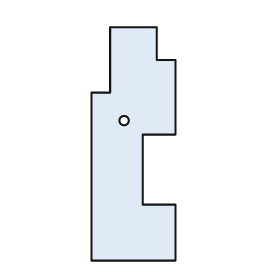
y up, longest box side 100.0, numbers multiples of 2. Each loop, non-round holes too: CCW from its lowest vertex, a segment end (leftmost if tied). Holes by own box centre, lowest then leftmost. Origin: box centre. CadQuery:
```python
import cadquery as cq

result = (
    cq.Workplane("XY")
    .moveTo(-18.0, -50.0)
    .lineTo(18.0, -50.0)
    .lineTo(18.0, -26.0)
    .lineTo(4.0, -26.0)
    .lineTo(4.0, 4.0)
    .lineTo(18.0, 4.0)
    .lineTo(18.0, 36.0)
    .lineTo(10.0, 36.0)
    .lineTo(10.0, 50.0)
    .lineTo(-10.0, 50.0)
    .lineTo(-10.0, 22.0)
    .lineTo(-18.0, 22.0)
    .close()
    .moveTo(-4.0, 10.0)
    .circle(2.0)
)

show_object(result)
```